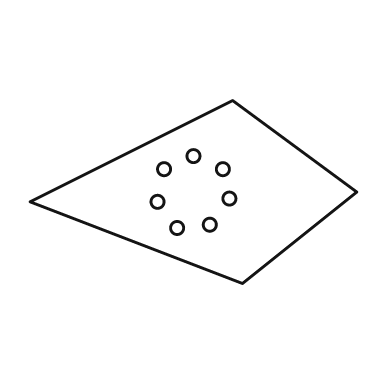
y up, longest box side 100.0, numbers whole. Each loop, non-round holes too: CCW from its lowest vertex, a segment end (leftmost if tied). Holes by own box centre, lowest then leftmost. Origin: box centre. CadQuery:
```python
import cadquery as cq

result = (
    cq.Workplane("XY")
    .moveTo(15.0, -28.0)
    .lineTo(50.0, 0.0)
    .lineTo(12.0, 28.0)
    .lineTo(-50.0, -3.0)
    .close()
    .moveTo(-5.0, -11.0)
    .circle(2.0)
    .moveTo(5.0, -10.0)
    .circle(2.0)
    .moveTo(-11.0, -3.0)
    .circle(2.0)
    .moveTo(11.0, -2.0)
    .circle(2.0)
    .moveTo(-9.0, 7.0)
    .circle(2.0)
    .moveTo(9.0, 7.0)
    .circle(2.0)
    .moveTo(0.0, 11.0)
    .circle(2.0)
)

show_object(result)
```